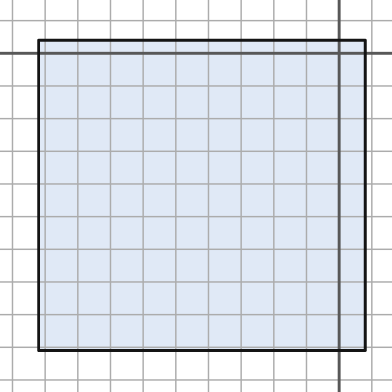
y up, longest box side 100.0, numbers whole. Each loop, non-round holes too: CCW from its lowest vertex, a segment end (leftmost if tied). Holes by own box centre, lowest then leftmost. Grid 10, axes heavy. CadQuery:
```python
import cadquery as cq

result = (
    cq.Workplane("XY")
    .moveTo(-92.0, -91.0)
    .lineTo(8.0, -91.0)
    .lineTo(8.0, 4.0)
    .lineTo(-92.0, 4.0)
    .close()
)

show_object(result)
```